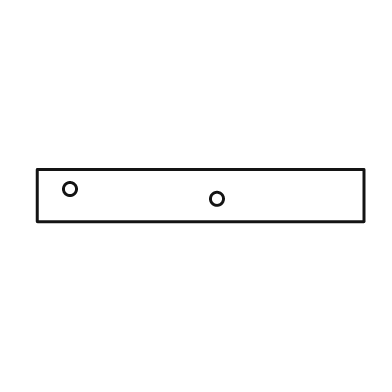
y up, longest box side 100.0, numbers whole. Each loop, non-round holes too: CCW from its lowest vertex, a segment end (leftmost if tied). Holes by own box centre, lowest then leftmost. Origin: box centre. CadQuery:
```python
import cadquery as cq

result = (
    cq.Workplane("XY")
    .moveTo(-50.0, -8.0)
    .lineTo(50.0, -8.0)
    .lineTo(50.0, 8.0)
    .lineTo(-50.0, 8.0)
    .close()
    .moveTo(5.0, -1.0)
    .circle(2.0)
    .moveTo(-40.0, 2.0)
    .circle(2.0)
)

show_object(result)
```